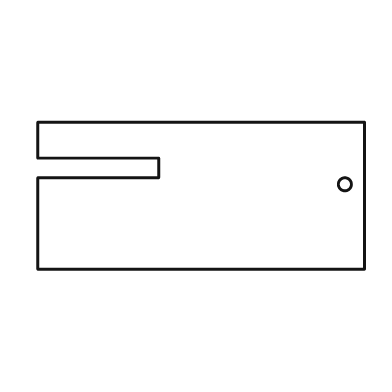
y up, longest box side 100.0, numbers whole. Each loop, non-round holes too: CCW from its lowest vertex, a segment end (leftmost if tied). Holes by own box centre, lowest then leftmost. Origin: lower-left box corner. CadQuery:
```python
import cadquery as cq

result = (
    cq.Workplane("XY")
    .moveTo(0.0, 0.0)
    .lineTo(100.0, 0.0)
    .lineTo(100.0, 45.0)
    .lineTo(0.0, 45.0)
    .lineTo(0.0, 34.0)
    .lineTo(37.0, 34.0)
    .lineTo(37.0, 28.0)
    .lineTo(0.0, 28.0)
    .close()
    .moveTo(94.0, 26.0)
    .circle(2.0)
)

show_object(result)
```